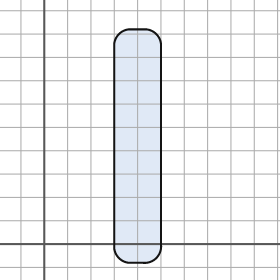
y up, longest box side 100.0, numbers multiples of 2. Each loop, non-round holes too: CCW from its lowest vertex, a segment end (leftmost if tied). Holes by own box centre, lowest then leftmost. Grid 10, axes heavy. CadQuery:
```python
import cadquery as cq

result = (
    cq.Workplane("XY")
    .moveTo(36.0, -8.0)
    .lineTo(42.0, -8.0)
    .threePointArc((48.0, -6.0), (50.0, 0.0))
    .lineTo(50.0, 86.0)
    .threePointArc((48.0, 90.0), (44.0, 92.0))
    .lineTo(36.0, 92.0)
    .threePointArc((32.0, 90.0), (30.0, 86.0))
    .lineTo(30.0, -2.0)
    .threePointArc((32.0, -6.0), (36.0, -8.0))
    .close()
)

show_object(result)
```